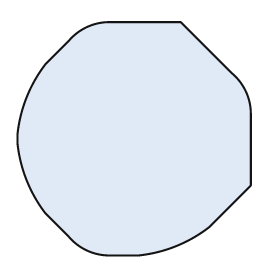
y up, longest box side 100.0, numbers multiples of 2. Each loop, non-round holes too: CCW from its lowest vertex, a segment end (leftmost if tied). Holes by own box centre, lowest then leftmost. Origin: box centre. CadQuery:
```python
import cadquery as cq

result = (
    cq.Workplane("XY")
    .moveTo(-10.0, -50.0)
    .lineTo(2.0, -50.0)
    .threePointArc((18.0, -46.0), (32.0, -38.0))
    .lineTo(50.0, -20.0)
    .lineTo(50.0, 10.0)
    .threePointArc((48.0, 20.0), (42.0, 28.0))
    .lineTo(20.0, 50.0)
    .lineTo(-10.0, 50.0)
    .threePointArc((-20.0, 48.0), (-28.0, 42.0))
    .lineTo(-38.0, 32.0)
    .threePointArc((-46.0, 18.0), (-50.0, 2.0))
    .lineTo(-50.0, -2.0)
    .threePointArc((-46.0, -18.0), (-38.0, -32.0))
    .lineTo(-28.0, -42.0)
    .threePointArc((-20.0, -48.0), (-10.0, -50.0))
    .close()
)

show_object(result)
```